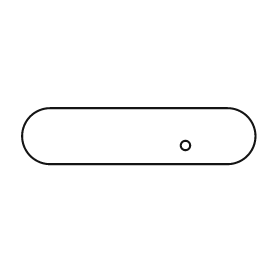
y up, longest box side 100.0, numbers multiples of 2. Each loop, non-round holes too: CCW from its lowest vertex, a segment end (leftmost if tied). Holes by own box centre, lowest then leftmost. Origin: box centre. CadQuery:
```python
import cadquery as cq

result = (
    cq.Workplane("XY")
    .moveTo(-38.0, -12.0)
    .lineTo(38.0, -12.0)
    .threePointArc((50.0, 0.0), (38.0, 12.0))
    .lineTo(-38.0, 12.0)
    .threePointArc((-50.0, 0.0), (-38.0, -12.0))
    .close()
    .moveTo(20.0, -4.0)
    .circle(2.0)
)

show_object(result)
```